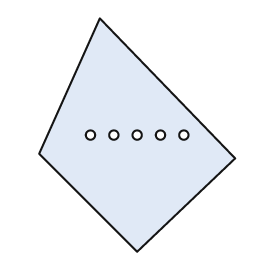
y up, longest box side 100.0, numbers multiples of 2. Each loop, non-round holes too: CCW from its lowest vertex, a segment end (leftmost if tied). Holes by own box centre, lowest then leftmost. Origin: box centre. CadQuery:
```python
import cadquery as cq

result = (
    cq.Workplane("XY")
    .moveTo(0.0, -50.0)
    .lineTo(42.0, -10.0)
    .lineTo(-16.0, 50.0)
    .lineTo(-42.0, -8.0)
    .close()
    .moveTo(-20.0, 0.0)
    .circle(2.0)
    .moveTo(-10.0, 0.0)
    .circle(2.0)
    .moveTo(0.0, 0.0)
    .circle(2.0)
    .moveTo(10.0, 0.0)
    .circle(2.0)
    .moveTo(20.0, 0.0)
    .circle(2.0)
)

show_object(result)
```